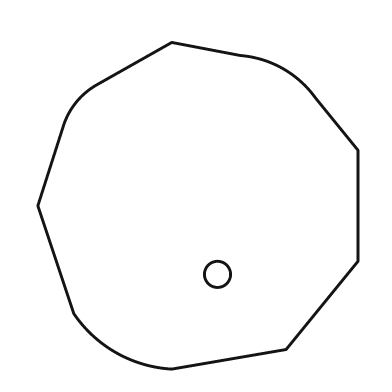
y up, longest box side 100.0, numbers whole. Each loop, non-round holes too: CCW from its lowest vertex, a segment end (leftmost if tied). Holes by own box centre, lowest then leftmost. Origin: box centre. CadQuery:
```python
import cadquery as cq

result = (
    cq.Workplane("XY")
    .moveTo(-8.0, -50.0)
    .lineTo(27.0, -44.0)
    .lineTo(49.0, -17.0)
    .lineTo(49.0, 17.0)
    .lineTo(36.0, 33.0)
    .threePointArc((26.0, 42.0), (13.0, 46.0))
    .lineTo(-8.0, 50.0)
    .lineTo(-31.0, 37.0)
    .threePointArc((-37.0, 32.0), (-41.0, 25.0))
    .lineTo(-49.0, 0.0)
    .lineTo(-38.0, -33.0)
    .threePointArc((-25.0, -45.0), (-8.0, -50.0))
    .close()
    .moveTo(6.0, -21.0)
    .circle(4.0)
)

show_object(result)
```